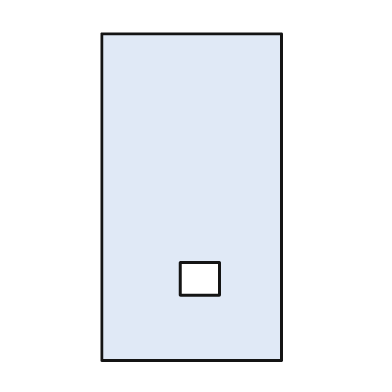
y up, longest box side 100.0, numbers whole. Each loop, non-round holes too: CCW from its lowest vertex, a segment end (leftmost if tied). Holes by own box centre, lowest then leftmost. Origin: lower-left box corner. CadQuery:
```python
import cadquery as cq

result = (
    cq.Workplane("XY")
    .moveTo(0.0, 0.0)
    .lineTo(55.0, 0.0)
    .lineTo(55.0, 100.0)
    .lineTo(0.0, 100.0)
    .close()
    .moveTo(24.0, 20.0)
    .lineTo(36.0, 20.0)
    .lineTo(36.0, 30.0)
    .lineTo(24.0, 30.0)
    .close()
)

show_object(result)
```